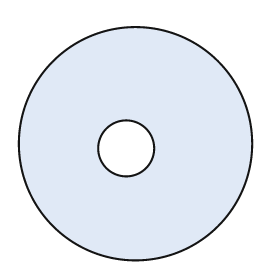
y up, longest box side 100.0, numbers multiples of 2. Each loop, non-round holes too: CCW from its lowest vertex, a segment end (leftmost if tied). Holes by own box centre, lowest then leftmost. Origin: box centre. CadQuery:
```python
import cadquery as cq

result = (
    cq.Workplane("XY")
    .moveTo(0.0, 0.0)
    .circle(50.0)
    .moveTo(-4.0, -2.0)
    .circle(12.0)
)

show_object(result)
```